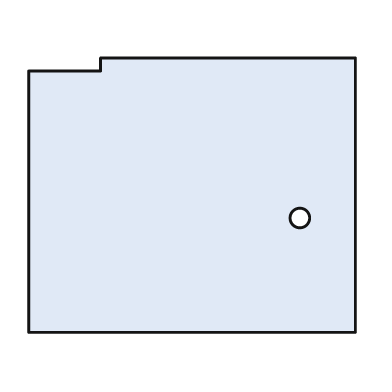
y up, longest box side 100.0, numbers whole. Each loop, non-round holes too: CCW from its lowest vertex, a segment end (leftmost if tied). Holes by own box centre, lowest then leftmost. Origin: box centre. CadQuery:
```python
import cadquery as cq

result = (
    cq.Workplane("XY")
    .moveTo(-50.0, -42.0)
    .lineTo(50.0, -42.0)
    .lineTo(50.0, 42.0)
    .lineTo(-28.0, 42.0)
    .lineTo(-28.0, 38.0)
    .lineTo(-50.0, 38.0)
    .close()
    .moveTo(33.0, -7.0)
    .circle(3.0)
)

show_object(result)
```